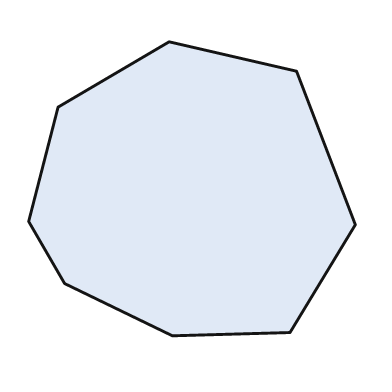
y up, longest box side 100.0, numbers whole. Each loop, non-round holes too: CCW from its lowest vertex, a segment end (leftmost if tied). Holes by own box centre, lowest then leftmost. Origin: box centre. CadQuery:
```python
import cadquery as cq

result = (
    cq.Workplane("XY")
    .moveTo(-6.0, -45.0)
    .lineTo(30.0, -44.0)
    .lineTo(50.0, -11.0)
    .lineTo(32.0, 36.0)
    .lineTo(-7.0, 45.0)
    .lineTo(-41.0, 25.0)
    .lineTo(-50.0, -10.0)
    .lineTo(-39.0, -29.0)
    .close()
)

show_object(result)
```